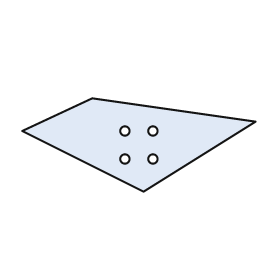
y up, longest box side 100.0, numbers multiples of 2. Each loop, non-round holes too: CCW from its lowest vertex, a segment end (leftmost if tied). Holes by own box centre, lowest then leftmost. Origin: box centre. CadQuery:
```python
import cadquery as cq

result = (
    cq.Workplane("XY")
    .moveTo(2.0, -20.0)
    .lineTo(50.0, 10.0)
    .lineTo(-20.0, 20.0)
    .lineTo(-50.0, 6.0)
    .close()
    .moveTo(-6.0, -6.0)
    .circle(2.0)
    .moveTo(6.0, -6.0)
    .circle(2.0)
    .moveTo(-6.0, 6.0)
    .circle(2.0)
    .moveTo(6.0, 6.0)
    .circle(2.0)
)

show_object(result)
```